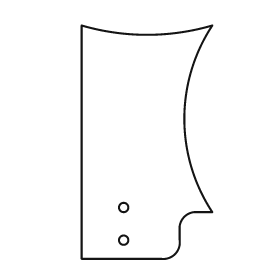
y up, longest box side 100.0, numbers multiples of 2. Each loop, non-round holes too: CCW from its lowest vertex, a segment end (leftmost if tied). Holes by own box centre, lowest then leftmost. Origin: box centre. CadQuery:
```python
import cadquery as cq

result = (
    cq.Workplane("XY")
    .moveTo(-28.0, -50.0)
    .lineTo(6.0, -50.0)
    .threePointArc((12.0, -48.0), (14.0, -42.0))
    .lineTo(14.0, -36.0)
    .threePointArc((16.0, -32.0), (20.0, -30.0))
    .lineTo(28.0, -30.0)
    .threePointArc((16.0, 10.0), (28.0, 50.0))
    .threePointArc((0.0, 46.0), (-28.0, 50.0))
    .close()
    .moveTo(-10.0, -42.0)
    .circle(2.0)
    .moveTo(-10.0, -28.0)
    .circle(2.0)
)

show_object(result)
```